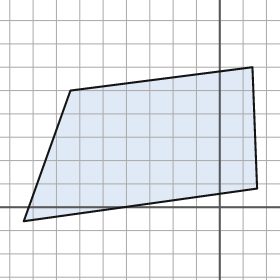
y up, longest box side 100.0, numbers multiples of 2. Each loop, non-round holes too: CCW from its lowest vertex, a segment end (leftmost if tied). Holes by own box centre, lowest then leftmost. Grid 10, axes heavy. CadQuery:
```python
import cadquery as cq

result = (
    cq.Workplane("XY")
    .moveTo(-84.0, -6.0)
    .lineTo(16.0, 8.0)
    .lineTo(14.0, 60.0)
    .lineTo(-64.0, 50.0)
    .close()
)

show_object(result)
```